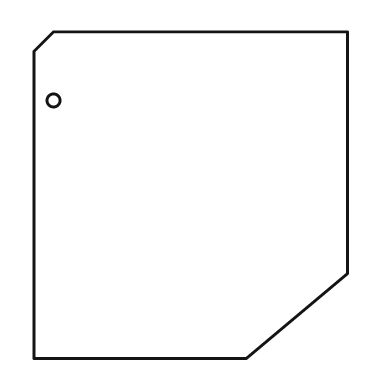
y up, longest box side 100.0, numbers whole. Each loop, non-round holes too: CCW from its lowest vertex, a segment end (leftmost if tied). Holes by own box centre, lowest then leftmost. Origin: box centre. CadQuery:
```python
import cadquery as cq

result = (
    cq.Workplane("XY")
    .moveTo(-48.0, -50.0)
    .lineTo(17.0, -50.0)
    .lineTo(48.0, -24.0)
    .lineTo(48.0, 50.0)
    .lineTo(-42.0, 50.0)
    .lineTo(-48.0, 44.0)
    .close()
    .moveTo(-42.0, 29.0)
    .circle(2.0)
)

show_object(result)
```